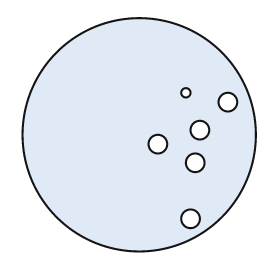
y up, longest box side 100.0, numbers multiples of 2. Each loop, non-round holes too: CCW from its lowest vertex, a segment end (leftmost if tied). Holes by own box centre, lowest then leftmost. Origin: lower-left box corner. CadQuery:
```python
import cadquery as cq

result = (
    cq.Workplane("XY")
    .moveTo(50.0, 50.0)
    .circle(50.0)
    .moveTo(72.0, 14.0)
    .circle(4.0)
    .moveTo(74.0, 38.0)
    .circle(4.0)
    .moveTo(58.0, 46.0)
    .circle(4.0)
    .moveTo(76.0, 52.0)
    .circle(4.0)
    .moveTo(88.0, 64.0)
    .circle(4.0)
    .moveTo(70.0, 68.0)
    .circle(2.0)
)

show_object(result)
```